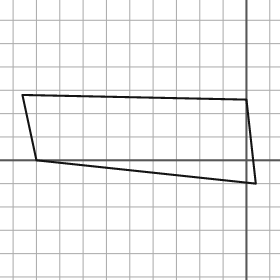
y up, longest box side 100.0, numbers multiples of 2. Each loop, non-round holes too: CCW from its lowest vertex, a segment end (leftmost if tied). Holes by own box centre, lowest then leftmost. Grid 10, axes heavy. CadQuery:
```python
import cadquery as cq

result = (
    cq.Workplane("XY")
    .moveTo(4.0, -10.0)
    .lineTo(0.0, 26.0)
    .lineTo(-96.0, 28.0)
    .lineTo(-90.0, 0.0)
    .close()
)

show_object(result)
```